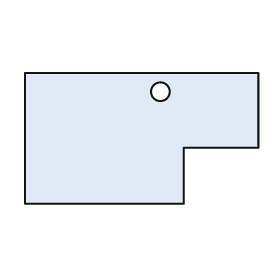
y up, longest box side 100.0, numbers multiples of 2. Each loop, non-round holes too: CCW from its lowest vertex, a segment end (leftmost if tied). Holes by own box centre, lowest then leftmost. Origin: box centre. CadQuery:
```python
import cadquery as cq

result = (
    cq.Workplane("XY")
    .moveTo(-50.0, -28.0)
    .lineTo(18.0, -28.0)
    .lineTo(18.0, -4.0)
    .lineTo(50.0, -4.0)
    .lineTo(50.0, 28.0)
    .lineTo(-50.0, 28.0)
    .close()
    .moveTo(8.0, 20.0)
    .circle(4.0)
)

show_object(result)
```